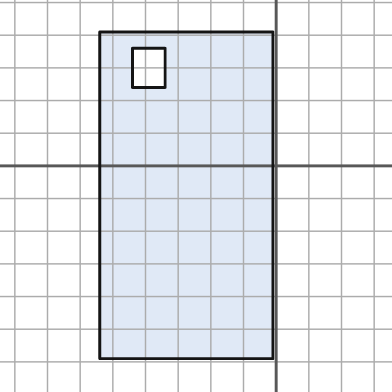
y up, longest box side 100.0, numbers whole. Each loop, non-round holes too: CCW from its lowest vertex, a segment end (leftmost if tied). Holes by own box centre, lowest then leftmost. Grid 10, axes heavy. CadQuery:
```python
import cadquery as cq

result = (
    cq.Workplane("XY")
    .moveTo(-54.0, -59.0)
    .lineTo(-1.0, -59.0)
    .lineTo(-1.0, 41.0)
    .lineTo(-54.0, 41.0)
    .close()
    .moveTo(-44.0, 24.0)
    .lineTo(-34.0, 24.0)
    .lineTo(-34.0, 36.0)
    .lineTo(-44.0, 36.0)
    .close()
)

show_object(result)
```